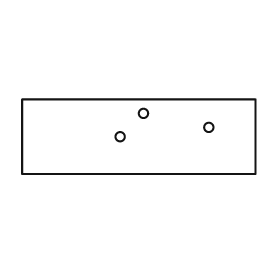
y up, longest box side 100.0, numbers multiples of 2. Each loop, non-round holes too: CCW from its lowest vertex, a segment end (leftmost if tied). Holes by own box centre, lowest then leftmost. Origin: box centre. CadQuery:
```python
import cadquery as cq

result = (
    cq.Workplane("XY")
    .moveTo(-50.0, -16.0)
    .lineTo(50.0, -16.0)
    .lineTo(50.0, 16.0)
    .lineTo(-50.0, 16.0)
    .close()
    .moveTo(-8.0, 0.0)
    .circle(2.0)
    .moveTo(30.0, 4.0)
    .circle(2.0)
    .moveTo(2.0, 10.0)
    .circle(2.0)
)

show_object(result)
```